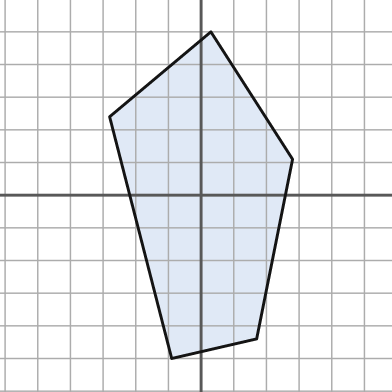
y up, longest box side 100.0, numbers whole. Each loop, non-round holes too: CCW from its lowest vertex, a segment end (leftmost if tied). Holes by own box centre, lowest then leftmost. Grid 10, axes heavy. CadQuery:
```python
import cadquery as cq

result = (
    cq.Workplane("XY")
    .moveTo(-9.0, -50.0)
    .lineTo(17.0, -44.0)
    .lineTo(28.0, 11.0)
    .lineTo(3.0, 50.0)
    .lineTo(-28.0, 24.0)
    .close()
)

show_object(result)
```